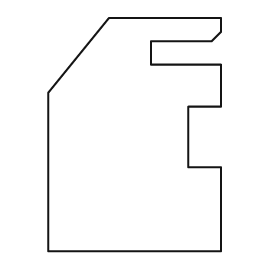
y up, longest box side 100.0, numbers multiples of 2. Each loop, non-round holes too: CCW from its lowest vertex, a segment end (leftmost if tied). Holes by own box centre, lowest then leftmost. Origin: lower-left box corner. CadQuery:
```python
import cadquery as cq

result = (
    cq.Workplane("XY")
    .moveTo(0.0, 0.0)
    .lineTo(74.0, 0.0)
    .lineTo(74.0, 36.0)
    .lineTo(60.0, 36.0)
    .lineTo(60.0, 62.0)
    .lineTo(74.0, 62.0)
    .lineTo(74.0, 80.0)
    .lineTo(44.0, 80.0)
    .lineTo(44.0, 90.0)
    .lineTo(70.0, 90.0)
    .lineTo(74.0, 94.0)
    .lineTo(74.0, 100.0)
    .lineTo(26.0, 100.0)
    .lineTo(0.0, 68.0)
    .close()
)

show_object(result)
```